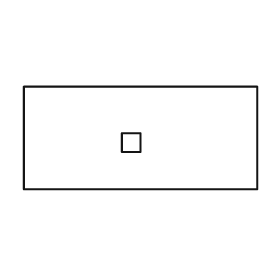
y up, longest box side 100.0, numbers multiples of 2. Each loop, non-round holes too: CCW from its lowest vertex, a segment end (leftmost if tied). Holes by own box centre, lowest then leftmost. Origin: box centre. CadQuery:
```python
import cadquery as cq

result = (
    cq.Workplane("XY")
    .moveTo(-50.0, -22.0)
    .lineTo(50.0, -22.0)
    .lineTo(50.0, 22.0)
    .lineTo(-50.0, 22.0)
    .close()
    .moveTo(-8.0, -6.0)
    .lineTo(0.0, -6.0)
    .lineTo(0.0, 2.0)
    .lineTo(-8.0, 2.0)
    .close()
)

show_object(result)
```